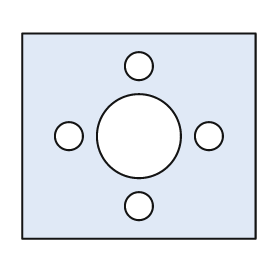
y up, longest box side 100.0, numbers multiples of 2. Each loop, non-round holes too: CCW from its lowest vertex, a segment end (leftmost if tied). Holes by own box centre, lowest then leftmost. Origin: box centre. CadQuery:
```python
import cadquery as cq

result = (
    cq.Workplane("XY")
    .moveTo(-50.0, -44.0)
    .lineTo(50.0, -44.0)
    .lineTo(50.0, 44.0)
    .lineTo(-50.0, 44.0)
    .close()
    .moveTo(0.0, -30.0)
    .circle(6.0)
    .moveTo(-30.0, 0.0)
    .circle(6.0)
    .moveTo(0.0, 0.0)
    .circle(18.0)
    .moveTo(30.0, 0.0)
    .circle(6.0)
    .moveTo(0.0, 30.0)
    .circle(6.0)
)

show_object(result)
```